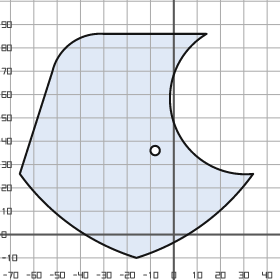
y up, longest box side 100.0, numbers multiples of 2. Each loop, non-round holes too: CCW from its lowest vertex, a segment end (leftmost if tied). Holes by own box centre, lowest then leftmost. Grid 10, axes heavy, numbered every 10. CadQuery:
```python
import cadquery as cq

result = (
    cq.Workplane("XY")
    .moveTo(-16.0, -10.0)
    .threePointArc((12.0, 4.0), (34.0, 26.0))
    .threePointArc((0.0, 48.0), (14.0, 86.0))
    .lineTo(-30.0, 86.0)
    .threePointArc((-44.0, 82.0), (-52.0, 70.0))
    .lineTo(-66.0, 26.0)
    .threePointArc((-44.0, 4.0), (-16.0, -10.0))
    .close()
    .moveTo(-8.0, 36.0)
    .circle(2.0)
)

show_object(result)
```